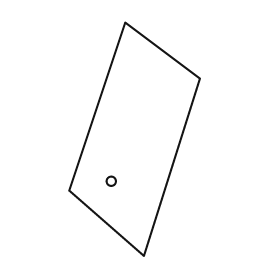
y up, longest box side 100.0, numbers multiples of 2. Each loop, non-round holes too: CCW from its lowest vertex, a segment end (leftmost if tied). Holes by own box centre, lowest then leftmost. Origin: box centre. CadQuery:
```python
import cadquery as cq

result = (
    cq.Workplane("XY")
    .moveTo(4.0, -50.0)
    .lineTo(28.0, 26.0)
    .lineTo(-4.0, 50.0)
    .lineTo(-28.0, -22.0)
    .close()
    .moveTo(-10.0, -18.0)
    .circle(2.0)
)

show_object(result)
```